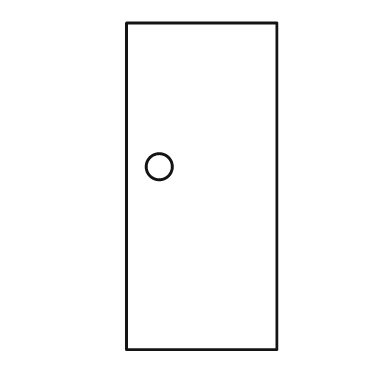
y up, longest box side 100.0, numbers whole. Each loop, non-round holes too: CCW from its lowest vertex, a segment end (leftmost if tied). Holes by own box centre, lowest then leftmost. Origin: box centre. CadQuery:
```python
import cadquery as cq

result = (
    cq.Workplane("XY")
    .moveTo(-23.0, -50.0)
    .lineTo(23.0, -50.0)
    .lineTo(23.0, 50.0)
    .lineTo(-23.0, 50.0)
    .close()
    .moveTo(-13.0, 6.0)
    .circle(4.0)
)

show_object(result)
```